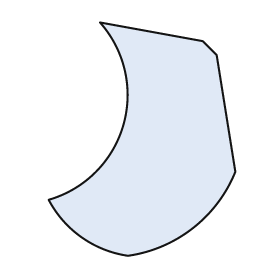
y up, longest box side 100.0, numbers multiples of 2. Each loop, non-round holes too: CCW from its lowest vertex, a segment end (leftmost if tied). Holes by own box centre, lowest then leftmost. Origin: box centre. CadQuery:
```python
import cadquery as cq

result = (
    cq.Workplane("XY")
    .moveTo(-6.0, -50.0)
    .threePointArc((22.0, -38.0), (40.0, -14.0))
    .lineTo(32.0, 36.0)
    .lineTo(26.0, 42.0)
    .lineTo(-18.0, 50.0)
    .threePointArc((-8.0, 6.0), (-40.0, -26.0))
    .threePointArc((-26.0, -42.0), (-6.0, -50.0))
    .close()
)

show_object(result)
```